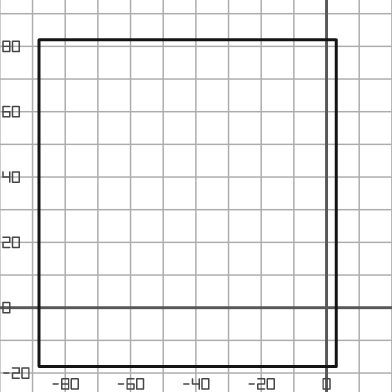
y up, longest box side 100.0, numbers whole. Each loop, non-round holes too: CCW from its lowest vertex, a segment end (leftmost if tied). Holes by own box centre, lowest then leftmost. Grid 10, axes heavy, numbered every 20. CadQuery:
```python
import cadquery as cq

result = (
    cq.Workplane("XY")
    .moveTo(-88.0, -18.0)
    .lineTo(3.0, -18.0)
    .lineTo(3.0, 82.0)
    .lineTo(-88.0, 82.0)
    .close()
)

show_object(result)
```